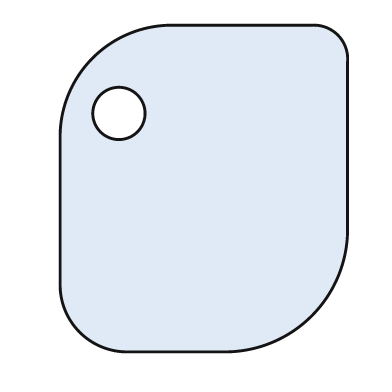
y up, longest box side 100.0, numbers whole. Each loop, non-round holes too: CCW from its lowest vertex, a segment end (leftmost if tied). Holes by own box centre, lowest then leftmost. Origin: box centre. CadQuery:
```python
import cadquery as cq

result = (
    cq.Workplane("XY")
    .moveTo(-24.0, -50.0)
    .lineTo(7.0, -50.0)
    .threePointArc((33.0, -39.0), (44.0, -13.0))
    .lineTo(44.0, 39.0)
    .threePointArc((41.0, 47.0), (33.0, 50.0))
    .lineTo(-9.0, 50.0)
    .threePointArc((-34.0, 40.0), (-44.0, 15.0))
    .lineTo(-44.0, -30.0)
    .threePointArc((-38.0, -44.0), (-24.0, -50.0))
    .close()
    .moveTo(-26.0, 23.0)
    .circle(8.0)
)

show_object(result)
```